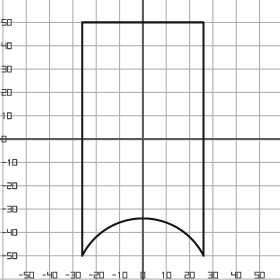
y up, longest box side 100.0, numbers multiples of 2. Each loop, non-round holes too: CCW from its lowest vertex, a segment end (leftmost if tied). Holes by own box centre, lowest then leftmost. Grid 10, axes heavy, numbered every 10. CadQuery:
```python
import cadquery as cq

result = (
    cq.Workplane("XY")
    .moveTo(-26.0, -50.0)
    .threePointArc((0.0, -34.0), (26.0, -50.0))
    .lineTo(26.0, 50.0)
    .lineTo(-26.0, 50.0)
    .close()
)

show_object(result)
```